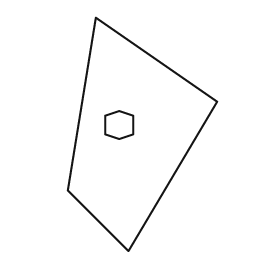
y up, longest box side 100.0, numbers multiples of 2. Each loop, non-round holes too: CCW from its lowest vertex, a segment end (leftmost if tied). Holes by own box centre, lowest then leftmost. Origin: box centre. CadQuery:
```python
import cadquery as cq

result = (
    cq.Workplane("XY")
    .moveTo(-6.0, -50.0)
    .lineTo(32.0, 14.0)
    .lineTo(-20.0, 50.0)
    .lineTo(-32.0, -24.0)
    .close()
    .moveTo(-10.0, -2.0)
    .lineTo(-4.0, 0.0)
    .lineTo(-4.0, 8.0)
    .lineTo(-10.0, 10.0)
    .lineTo(-16.0, 8.0)
    .lineTo(-16.0, 0.0)
    .close()
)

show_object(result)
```